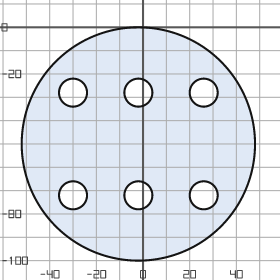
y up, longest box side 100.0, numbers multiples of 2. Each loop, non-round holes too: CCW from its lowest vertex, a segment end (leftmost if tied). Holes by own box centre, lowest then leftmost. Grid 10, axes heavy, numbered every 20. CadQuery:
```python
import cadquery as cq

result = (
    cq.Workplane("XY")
    .moveTo(-2.0, -50.0)
    .circle(50.0)
    .moveTo(-30.0, -72.0)
    .circle(6.0)
    .moveTo(-2.0, -72.0)
    .circle(6.0)
    .moveTo(26.0, -72.0)
    .circle(6.0)
    .moveTo(-30.0, -28.0)
    .circle(6.0)
    .moveTo(-2.0, -28.0)
    .circle(6.0)
    .moveTo(26.0, -28.0)
    .circle(6.0)
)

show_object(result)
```